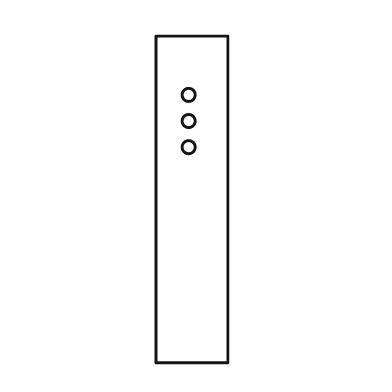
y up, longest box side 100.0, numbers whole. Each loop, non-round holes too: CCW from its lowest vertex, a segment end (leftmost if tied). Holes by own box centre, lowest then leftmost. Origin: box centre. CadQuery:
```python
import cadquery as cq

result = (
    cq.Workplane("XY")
    .moveTo(-11.0, -50.0)
    .lineTo(11.0, -50.0)
    .lineTo(11.0, 50.0)
    .lineTo(-11.0, 50.0)
    .close()
    .moveTo(-1.0, 16.0)
    .circle(2.0)
    .moveTo(-1.0, 24.0)
    .circle(2.0)
    .moveTo(-1.0, 32.0)
    .circle(2.0)
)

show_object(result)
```